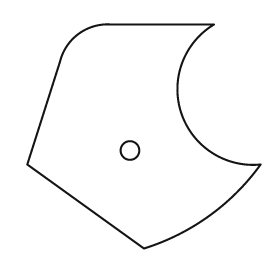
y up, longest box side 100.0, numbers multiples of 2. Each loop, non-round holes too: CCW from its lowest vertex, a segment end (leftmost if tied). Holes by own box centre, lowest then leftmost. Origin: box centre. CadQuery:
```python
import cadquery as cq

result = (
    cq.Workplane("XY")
    .moveTo(0.0, -48.0)
    .threePointArc((28.0, -34.0), (50.0, -12.0))
    .threePointArc((16.0, 10.0), (30.0, 48.0))
    .lineTo(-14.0, 48.0)
    .threePointArc((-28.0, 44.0), (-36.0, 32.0))
    .lineTo(-50.0, -12.0)
    .close()
    .moveTo(-6.0, -6.0)
    .circle(4.0)
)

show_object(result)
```